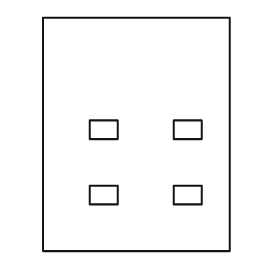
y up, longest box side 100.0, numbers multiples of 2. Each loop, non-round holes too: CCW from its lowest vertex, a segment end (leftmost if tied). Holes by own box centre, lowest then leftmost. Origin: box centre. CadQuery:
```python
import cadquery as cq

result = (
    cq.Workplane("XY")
    .moveTo(-40.0, -50.0)
    .lineTo(40.0, -50.0)
    .lineTo(40.0, 50.0)
    .lineTo(-40.0, 50.0)
    .close()
    .moveTo(-20.0, -30.0)
    .lineTo(-8.0, -30.0)
    .lineTo(-8.0, -22.0)
    .lineTo(-20.0, -22.0)
    .close()
    .moveTo(16.0, -30.0)
    .lineTo(28.0, -30.0)
    .lineTo(28.0, -22.0)
    .lineTo(16.0, -22.0)
    .close()
    .moveTo(-20.0, -2.0)
    .lineTo(-8.0, -2.0)
    .lineTo(-8.0, 6.0)
    .lineTo(-20.0, 6.0)
    .close()
    .moveTo(16.0, -2.0)
    .lineTo(28.0, -2.0)
    .lineTo(28.0, 6.0)
    .lineTo(16.0, 6.0)
    .close()
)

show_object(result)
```